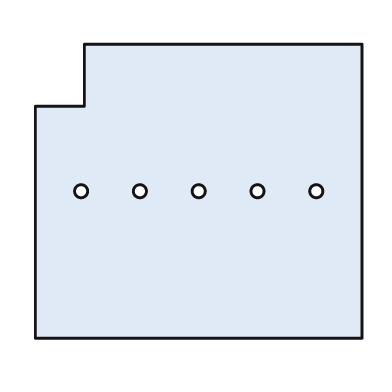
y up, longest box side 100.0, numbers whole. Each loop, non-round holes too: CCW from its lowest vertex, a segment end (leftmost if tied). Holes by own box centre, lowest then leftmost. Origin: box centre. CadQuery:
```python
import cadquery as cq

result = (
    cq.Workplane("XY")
    .moveTo(-50.0, -45.0)
    .lineTo(50.0, -45.0)
    .lineTo(50.0, 45.0)
    .lineTo(-35.0, 45.0)
    .lineTo(-35.0, 26.0)
    .lineTo(-50.0, 26.0)
    .close()
    .moveTo(-36.0, 0.0)
    .circle(2.0)
    .moveTo(-18.0, 0.0)
    .circle(2.0)
    .moveTo(0.0, 0.0)
    .circle(2.0)
    .moveTo(18.0, 0.0)
    .circle(2.0)
    .moveTo(36.0, 0.0)
    .circle(2.0)
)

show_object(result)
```